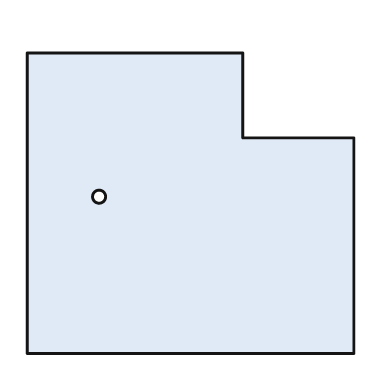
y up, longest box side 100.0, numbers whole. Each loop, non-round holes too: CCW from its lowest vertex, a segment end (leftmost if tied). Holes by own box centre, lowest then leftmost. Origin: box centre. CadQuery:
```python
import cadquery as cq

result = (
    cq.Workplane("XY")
    .moveTo(-50.0, -46.0)
    .lineTo(50.0, -46.0)
    .lineTo(50.0, 20.0)
    .lineTo(16.0, 20.0)
    .lineTo(16.0, 46.0)
    .lineTo(-50.0, 46.0)
    .close()
    .moveTo(-28.0, 2.0)
    .circle(2.0)
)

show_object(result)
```